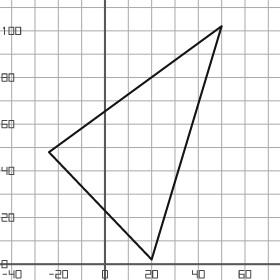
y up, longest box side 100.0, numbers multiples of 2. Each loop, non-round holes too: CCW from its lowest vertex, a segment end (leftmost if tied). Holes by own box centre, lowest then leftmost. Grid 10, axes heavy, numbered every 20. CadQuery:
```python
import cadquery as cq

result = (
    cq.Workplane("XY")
    .moveTo(20.0, 2.0)
    .lineTo(50.0, 102.0)
    .lineTo(-24.0, 48.0)
    .close()
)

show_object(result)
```